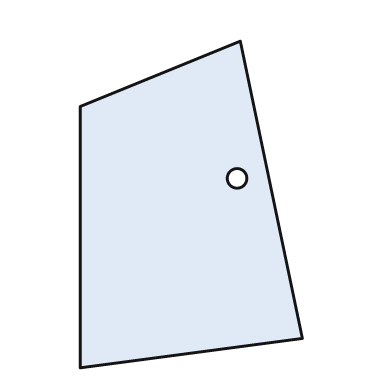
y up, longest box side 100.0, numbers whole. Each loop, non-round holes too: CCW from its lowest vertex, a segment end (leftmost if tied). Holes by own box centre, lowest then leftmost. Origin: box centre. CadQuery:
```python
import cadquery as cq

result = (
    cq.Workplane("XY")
    .moveTo(-34.0, -50.0)
    .lineTo(34.0, -41.0)
    .lineTo(15.0, 50.0)
    .lineTo(-34.0, 30.0)
    .close()
    .moveTo(14.0, 8.0)
    .circle(3.0)
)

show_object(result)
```